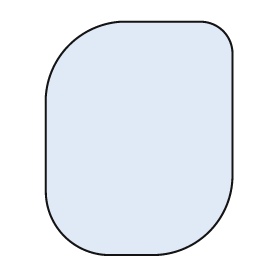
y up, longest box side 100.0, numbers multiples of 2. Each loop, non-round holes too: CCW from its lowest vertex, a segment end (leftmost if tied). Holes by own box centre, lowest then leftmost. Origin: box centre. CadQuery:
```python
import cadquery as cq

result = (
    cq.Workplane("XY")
    .moveTo(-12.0, -50.0)
    .lineTo(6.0, -50.0)
    .threePointArc((30.0, -40.0), (40.0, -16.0))
    .lineTo(40.0, 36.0)
    .threePointArc((36.0, 46.0), (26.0, 50.0))
    .lineTo(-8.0, 50.0)
    .threePointArc((-30.0, 40.0), (-40.0, 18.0))
    .lineTo(-40.0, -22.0)
    .threePointArc((-32.0, -42.0), (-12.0, -50.0))
    .close()
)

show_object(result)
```